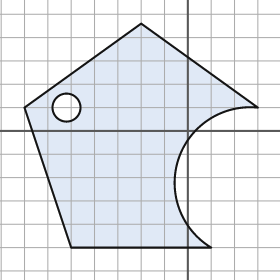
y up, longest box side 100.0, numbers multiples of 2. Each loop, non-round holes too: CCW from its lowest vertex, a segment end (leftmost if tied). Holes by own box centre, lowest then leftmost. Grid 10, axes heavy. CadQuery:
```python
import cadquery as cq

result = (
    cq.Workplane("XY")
    .moveTo(-50.0, -50.0)
    .lineTo(10.0, -50.0)
    .threePointArc((-4.0, -12.0), (30.0, 10.0))
    .lineTo(-20.0, 46.0)
    .lineTo(-70.0, 10.0)
    .close()
    .moveTo(-52.0, 10.0)
    .circle(6.0)
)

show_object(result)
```